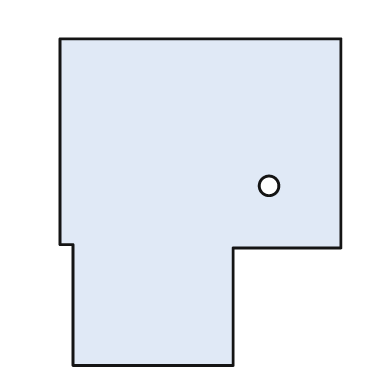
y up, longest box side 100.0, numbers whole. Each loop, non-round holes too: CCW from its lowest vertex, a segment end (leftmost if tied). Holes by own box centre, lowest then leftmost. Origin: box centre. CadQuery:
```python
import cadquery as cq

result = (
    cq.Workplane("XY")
    .moveTo(-39.0, -50.0)
    .lineTo(10.0, -50.0)
    .lineTo(10.0, -14.0)
    .lineTo(43.0, -14.0)
    .lineTo(43.0, 50.0)
    .lineTo(-43.0, 50.0)
    .lineTo(-43.0, -13.0)
    .lineTo(-39.0, -13.0)
    .close()
    .moveTo(21.0, 5.0)
    .circle(3.0)
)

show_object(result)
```